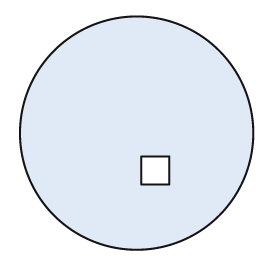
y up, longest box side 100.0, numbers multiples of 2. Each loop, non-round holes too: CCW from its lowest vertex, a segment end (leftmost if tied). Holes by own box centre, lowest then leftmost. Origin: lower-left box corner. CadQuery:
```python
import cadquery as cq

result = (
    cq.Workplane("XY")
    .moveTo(50.0, 50.0)
    .circle(50.0)
    .moveTo(52.0, 28.0)
    .lineTo(64.0, 28.0)
    .lineTo(64.0, 40.0)
    .lineTo(52.0, 40.0)
    .close()
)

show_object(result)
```